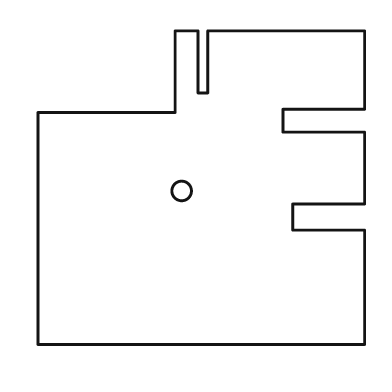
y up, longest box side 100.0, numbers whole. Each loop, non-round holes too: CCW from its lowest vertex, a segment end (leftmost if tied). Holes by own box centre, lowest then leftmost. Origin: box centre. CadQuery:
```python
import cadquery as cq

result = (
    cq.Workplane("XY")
    .moveTo(-50.0, -48.0)
    .lineTo(50.0, -48.0)
    .lineTo(50.0, -13.0)
    .lineTo(28.0, -13.0)
    .lineTo(28.0, -5.0)
    .lineTo(50.0, -5.0)
    .lineTo(50.0, 17.0)
    .lineTo(25.0, 17.0)
    .lineTo(25.0, 24.0)
    .lineTo(50.0, 24.0)
    .lineTo(50.0, 48.0)
    .lineTo(2.0, 48.0)
    .lineTo(2.0, 29.0)
    .lineTo(-1.0, 29.0)
    .lineTo(-1.0, 48.0)
    .lineTo(-8.0, 48.0)
    .lineTo(-8.0, 23.0)
    .lineTo(-50.0, 23.0)
    .close()
    .moveTo(-6.0, -1.0)
    .circle(3.0)
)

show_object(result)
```